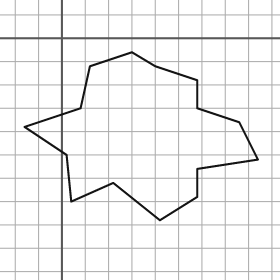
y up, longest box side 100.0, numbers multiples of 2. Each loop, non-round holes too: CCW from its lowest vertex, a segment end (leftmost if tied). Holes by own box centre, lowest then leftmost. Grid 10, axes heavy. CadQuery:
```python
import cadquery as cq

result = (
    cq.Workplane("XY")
    .moveTo(42.0, -78.0)
    .lineTo(58.0, -68.0)
    .lineTo(58.0, -56.0)
    .lineTo(84.0, -52.0)
    .lineTo(76.0, -36.0)
    .lineTo(58.0, -30.0)
    .lineTo(58.0, -18.0)
    .lineTo(40.0, -12.0)
    .lineTo(30.0, -6.0)
    .lineTo(12.0, -12.0)
    .lineTo(8.0, -30.0)
    .lineTo(-16.0, -38.0)
    .lineTo(2.0, -50.0)
    .lineTo(4.0, -70.0)
    .lineTo(22.0, -62.0)
    .close()
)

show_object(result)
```